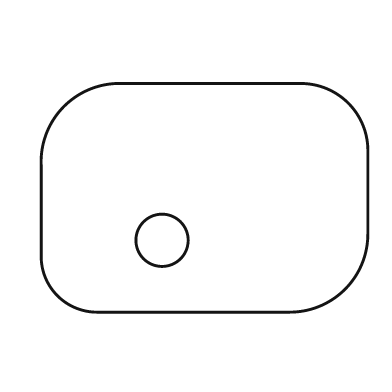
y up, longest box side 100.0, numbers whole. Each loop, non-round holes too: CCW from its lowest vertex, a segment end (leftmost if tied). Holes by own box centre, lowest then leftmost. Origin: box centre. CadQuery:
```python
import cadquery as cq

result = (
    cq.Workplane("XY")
    .moveTo(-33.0, -35.0)
    .lineTo(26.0, -35.0)
    .threePointArc((43.0, -28.0), (50.0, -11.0))
    .lineTo(50.0, 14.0)
    .threePointArc((44.0, 29.0), (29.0, 35.0))
    .lineTo(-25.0, 35.0)
    .threePointArc((-43.0, 28.0), (-50.0, 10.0))
    .lineTo(-50.0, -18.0)
    .threePointArc((-45.0, -30.0), (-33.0, -35.0))
    .close()
    .moveTo(-13.0, -13.0)
    .circle(8.0)
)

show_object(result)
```